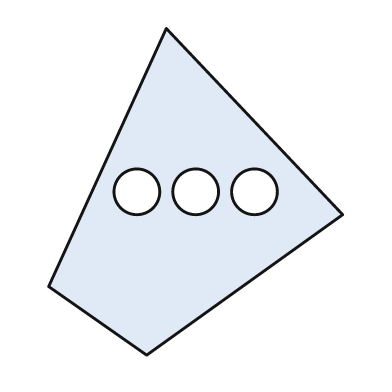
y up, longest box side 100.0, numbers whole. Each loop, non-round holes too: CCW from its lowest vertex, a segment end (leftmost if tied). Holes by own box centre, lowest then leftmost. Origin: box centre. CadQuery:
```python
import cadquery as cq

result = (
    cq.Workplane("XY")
    .moveTo(-15.0, -50.0)
    .lineTo(45.0, -7.0)
    .lineTo(-9.0, 50.0)
    .lineTo(-45.0, -29.0)
    .close()
    .moveTo(-18.0, 0.0)
    .circle(7.0)
    .moveTo(0.0, 0.0)
    .circle(7.0)
    .moveTo(18.0, 0.0)
    .circle(7.0)
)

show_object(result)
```